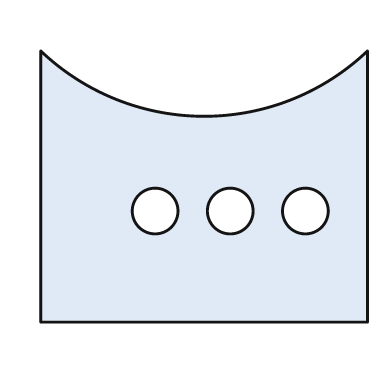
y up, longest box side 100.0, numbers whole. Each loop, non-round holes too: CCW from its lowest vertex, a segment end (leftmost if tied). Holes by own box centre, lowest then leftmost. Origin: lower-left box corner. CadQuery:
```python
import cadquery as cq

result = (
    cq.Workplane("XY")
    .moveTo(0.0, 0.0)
    .lineTo(100.0, 0.0)
    .lineTo(100.0, 83.0)
    .threePointArc((50.0, 63.0), (0.0, 83.0))
    .close()
    .moveTo(35.0, 34.0)
    .circle(7.0)
    .moveTo(58.0, 34.0)
    .circle(7.0)
    .moveTo(81.0, 34.0)
    .circle(7.0)
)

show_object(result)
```